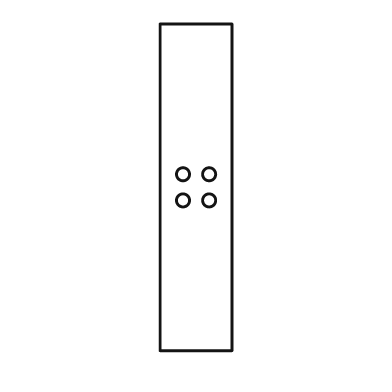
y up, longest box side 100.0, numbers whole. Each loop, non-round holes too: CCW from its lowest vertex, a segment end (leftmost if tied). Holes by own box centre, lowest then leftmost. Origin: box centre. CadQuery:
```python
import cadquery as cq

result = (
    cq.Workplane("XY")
    .moveTo(-11.0, -50.0)
    .lineTo(11.0, -50.0)
    .lineTo(11.0, 50.0)
    .lineTo(-11.0, 50.0)
    .close()
    .moveTo(-4.0, -4.0)
    .circle(2.0)
    .moveTo(4.0, -4.0)
    .circle(2.0)
    .moveTo(-4.0, 4.0)
    .circle(2.0)
    .moveTo(4.0, 4.0)
    .circle(2.0)
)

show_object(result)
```